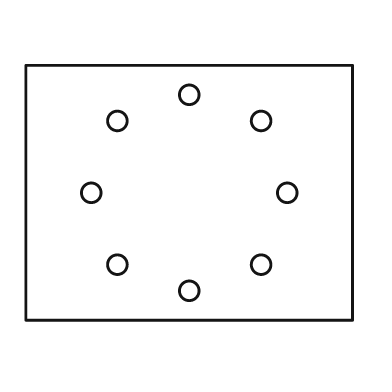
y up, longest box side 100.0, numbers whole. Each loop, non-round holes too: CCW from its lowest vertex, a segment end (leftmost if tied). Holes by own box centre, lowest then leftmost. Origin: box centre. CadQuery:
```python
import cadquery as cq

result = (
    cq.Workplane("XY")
    .moveTo(-50.0, -39.0)
    .lineTo(50.0, -39.0)
    .lineTo(50.0, 39.0)
    .lineTo(-50.0, 39.0)
    .close()
    .moveTo(0.0, -30.0)
    .circle(3.0)
    .moveTo(-22.0, -22.0)
    .circle(3.0)
    .moveTo(22.0, -22.0)
    .circle(3.0)
    .moveTo(-30.0, 0.0)
    .circle(3.0)
    .moveTo(30.0, 0.0)
    .circle(3.0)
    .moveTo(-22.0, 22.0)
    .circle(3.0)
    .moveTo(22.0, 22.0)
    .circle(3.0)
    .moveTo(0.0, 30.0)
    .circle(3.0)
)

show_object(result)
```